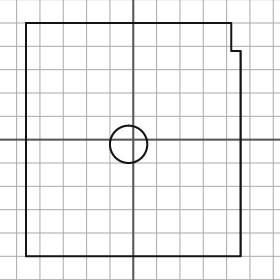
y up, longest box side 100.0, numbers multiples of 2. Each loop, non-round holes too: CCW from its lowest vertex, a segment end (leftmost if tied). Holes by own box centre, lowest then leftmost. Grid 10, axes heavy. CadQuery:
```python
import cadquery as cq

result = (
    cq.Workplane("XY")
    .moveTo(-46.0, -50.0)
    .lineTo(46.0, -50.0)
    .lineTo(46.0, 38.0)
    .lineTo(42.0, 38.0)
    .lineTo(42.0, 50.0)
    .lineTo(-46.0, 50.0)
    .close()
    .moveTo(-2.0, -2.0)
    .circle(8.0)
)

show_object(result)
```